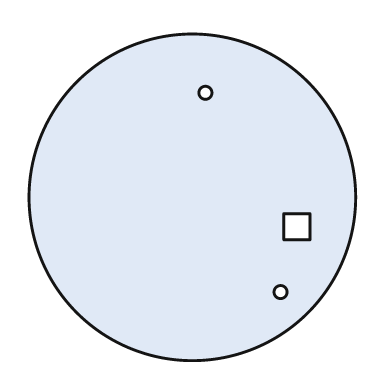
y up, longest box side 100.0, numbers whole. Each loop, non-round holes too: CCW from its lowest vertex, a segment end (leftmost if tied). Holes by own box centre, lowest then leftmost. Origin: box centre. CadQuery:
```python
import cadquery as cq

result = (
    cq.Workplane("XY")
    .moveTo(0.0, 0.0)
    .circle(50.0)
    .moveTo(27.0, -29.0)
    .circle(2.0)
    .moveTo(28.0, -13.0)
    .lineTo(36.0, -13.0)
    .lineTo(36.0, -5.0)
    .lineTo(28.0, -5.0)
    .close()
    .moveTo(4.0, 32.0)
    .circle(2.0)
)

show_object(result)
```